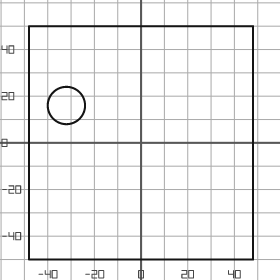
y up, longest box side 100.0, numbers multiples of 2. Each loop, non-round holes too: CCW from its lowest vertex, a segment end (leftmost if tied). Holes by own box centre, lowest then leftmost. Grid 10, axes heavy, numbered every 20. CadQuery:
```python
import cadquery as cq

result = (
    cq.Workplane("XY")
    .moveTo(-48.0, -50.0)
    .lineTo(48.0, -50.0)
    .lineTo(48.0, 50.0)
    .lineTo(-48.0, 50.0)
    .close()
    .moveTo(-32.0, 16.0)
    .circle(8.0)
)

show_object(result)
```